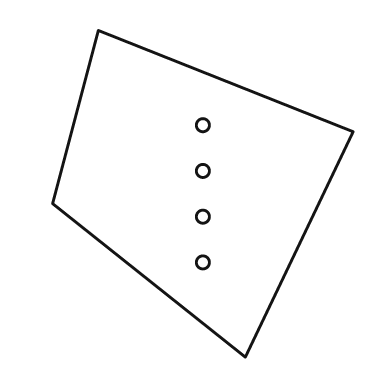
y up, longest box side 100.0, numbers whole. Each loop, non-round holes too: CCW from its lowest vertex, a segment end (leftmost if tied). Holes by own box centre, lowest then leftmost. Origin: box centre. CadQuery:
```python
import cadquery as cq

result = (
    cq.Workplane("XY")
    .moveTo(13.0, -50.0)
    .lineTo(46.0, 19.0)
    .lineTo(-32.0, 50.0)
    .lineTo(-46.0, -3.0)
    .close()
    .moveTo(0.0, -21.0)
    .circle(2.0)
    .moveTo(0.0, -7.0)
    .circle(2.0)
    .moveTo(0.0, 7.0)
    .circle(2.0)
    .moveTo(0.0, 21.0)
    .circle(2.0)
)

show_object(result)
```